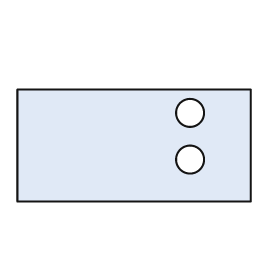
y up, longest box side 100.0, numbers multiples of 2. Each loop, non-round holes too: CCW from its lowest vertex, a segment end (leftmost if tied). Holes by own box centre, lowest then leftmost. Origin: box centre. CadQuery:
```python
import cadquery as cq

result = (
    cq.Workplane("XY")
    .moveTo(-50.0, -24.0)
    .lineTo(50.0, -24.0)
    .lineTo(50.0, 24.0)
    .lineTo(-50.0, 24.0)
    .close()
    .moveTo(24.0, -6.0)
    .circle(6.0)
    .moveTo(24.0, 14.0)
    .circle(6.0)
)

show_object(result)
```